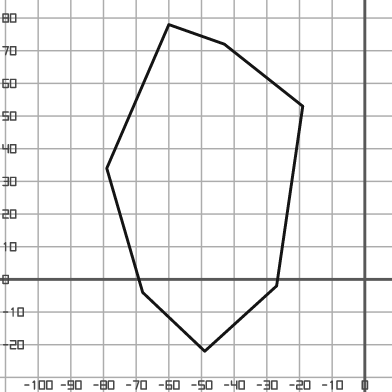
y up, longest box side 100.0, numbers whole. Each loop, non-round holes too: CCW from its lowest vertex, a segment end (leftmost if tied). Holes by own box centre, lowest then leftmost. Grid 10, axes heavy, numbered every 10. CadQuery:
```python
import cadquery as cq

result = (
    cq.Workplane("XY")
    .moveTo(-49.0, -22.0)
    .lineTo(-27.0, -2.0)
    .lineTo(-19.0, 53.0)
    .lineTo(-43.0, 72.0)
    .lineTo(-60.0, 78.0)
    .lineTo(-79.0, 34.0)
    .lineTo(-68.0, -4.0)
    .close()
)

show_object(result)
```